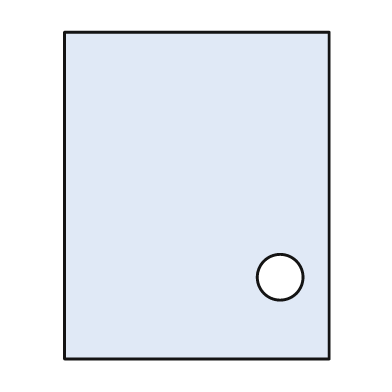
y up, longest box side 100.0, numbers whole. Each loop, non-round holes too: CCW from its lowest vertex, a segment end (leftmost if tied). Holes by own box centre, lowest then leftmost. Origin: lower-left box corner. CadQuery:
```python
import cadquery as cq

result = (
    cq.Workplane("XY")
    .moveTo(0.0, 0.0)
    .lineTo(81.0, 0.0)
    .lineTo(81.0, 100.0)
    .lineTo(0.0, 100.0)
    .close()
    .moveTo(66.0, 25.0)
    .circle(7.0)
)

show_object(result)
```